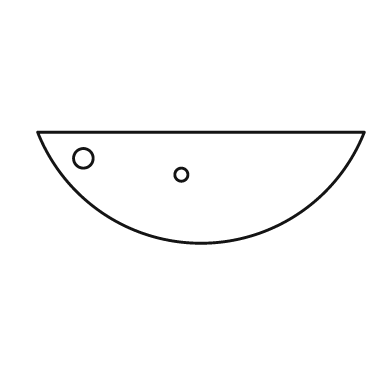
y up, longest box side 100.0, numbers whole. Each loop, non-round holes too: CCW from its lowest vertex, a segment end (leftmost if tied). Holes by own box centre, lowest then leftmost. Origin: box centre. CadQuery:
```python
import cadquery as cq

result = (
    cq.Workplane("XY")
    .moveTo(-50.0, 17.0)
    .threePointArc((0.0, -17.0), (50.0, 17.0))
    .close()
    .moveTo(-6.0, 4.0)
    .circle(2.0)
    .moveTo(-36.0, 9.0)
    .circle(3.0)
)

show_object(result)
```